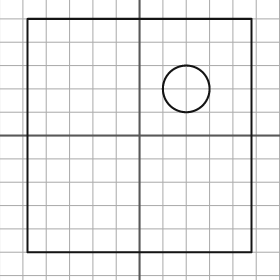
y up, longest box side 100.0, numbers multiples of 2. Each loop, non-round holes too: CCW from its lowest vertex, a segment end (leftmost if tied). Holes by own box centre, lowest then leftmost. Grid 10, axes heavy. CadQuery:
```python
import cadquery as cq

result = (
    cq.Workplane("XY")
    .moveTo(-48.0, -50.0)
    .lineTo(48.0, -50.0)
    .lineTo(48.0, 50.0)
    .lineTo(-48.0, 50.0)
    .close()
    .moveTo(20.0, 20.0)
    .circle(10.0)
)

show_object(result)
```